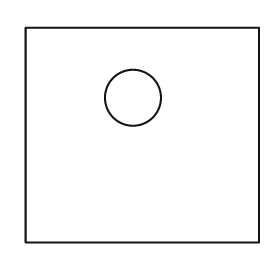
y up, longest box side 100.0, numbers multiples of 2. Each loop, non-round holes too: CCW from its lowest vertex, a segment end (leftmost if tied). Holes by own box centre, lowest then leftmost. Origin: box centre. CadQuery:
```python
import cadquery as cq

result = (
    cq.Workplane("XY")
    .moveTo(-50.0, -46.0)
    .lineTo(50.0, -46.0)
    .lineTo(50.0, 46.0)
    .lineTo(-50.0, 46.0)
    .close()
    .moveTo(-4.0, 16.0)
    .circle(12.0)
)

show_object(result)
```